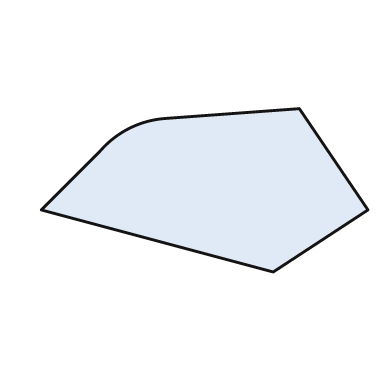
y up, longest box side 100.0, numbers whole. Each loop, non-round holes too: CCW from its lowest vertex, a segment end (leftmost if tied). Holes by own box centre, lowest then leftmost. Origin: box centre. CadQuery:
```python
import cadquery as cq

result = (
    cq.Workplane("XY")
    .moveTo(21.0, -25.0)
    .lineTo(50.0, -6.0)
    .lineTo(29.0, 25.0)
    .lineTo(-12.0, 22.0)
    .threePointArc((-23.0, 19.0), (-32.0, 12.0))
    .lineTo(-50.0, -6.0)
    .close()
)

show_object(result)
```